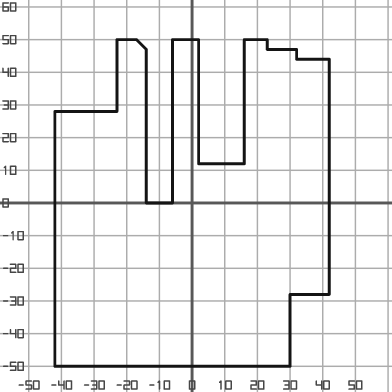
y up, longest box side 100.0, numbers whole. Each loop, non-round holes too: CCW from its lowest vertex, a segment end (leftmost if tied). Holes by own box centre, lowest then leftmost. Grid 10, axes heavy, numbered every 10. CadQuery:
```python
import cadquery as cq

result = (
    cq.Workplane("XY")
    .moveTo(-42.0, -50.0)
    .lineTo(30.0, -50.0)
    .lineTo(30.0, -28.0)
    .lineTo(42.0, -28.0)
    .lineTo(42.0, 44.0)
    .lineTo(32.0, 44.0)
    .lineTo(32.0, 47.0)
    .lineTo(23.0, 47.0)
    .lineTo(23.0, 50.0)
    .lineTo(16.0, 50.0)
    .lineTo(16.0, 12.0)
    .lineTo(2.0, 12.0)
    .lineTo(2.0, 50.0)
    .lineTo(-6.0, 50.0)
    .lineTo(-6.0, 0.0)
    .lineTo(-14.0, 0.0)
    .lineTo(-14.0, 47.0)
    .lineTo(-17.0, 50.0)
    .lineTo(-23.0, 50.0)
    .lineTo(-23.0, 28.0)
    .lineTo(-42.0, 28.0)
    .close()
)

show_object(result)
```